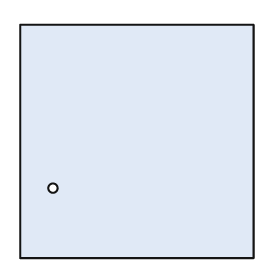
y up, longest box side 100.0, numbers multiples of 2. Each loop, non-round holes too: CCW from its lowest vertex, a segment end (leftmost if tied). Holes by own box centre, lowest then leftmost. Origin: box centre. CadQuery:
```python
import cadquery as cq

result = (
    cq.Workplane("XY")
    .moveTo(-50.0, -50.0)
    .lineTo(50.0, -50.0)
    .lineTo(50.0, 50.0)
    .lineTo(-50.0, 50.0)
    .close()
    .moveTo(-36.0, -20.0)
    .circle(2.0)
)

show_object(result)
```